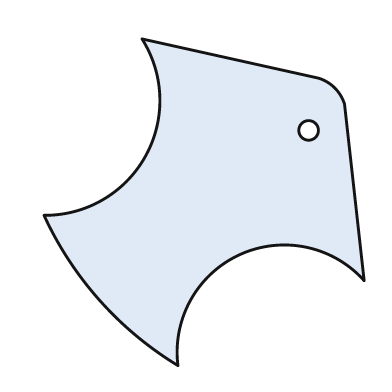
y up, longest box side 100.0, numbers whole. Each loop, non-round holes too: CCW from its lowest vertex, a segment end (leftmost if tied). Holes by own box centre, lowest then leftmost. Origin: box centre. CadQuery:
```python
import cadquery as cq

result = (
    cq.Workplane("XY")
    .moveTo(-8.0, -50.0)
    .threePointArc((11.0, -16.0), (49.0, -24.0))
    .lineTo(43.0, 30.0)
    .threePointArc((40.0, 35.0), (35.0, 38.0))
    .lineTo(-19.0, 50.0)
    .threePointArc((-18.0, 14.0), (-49.0, -4.0))
    .threePointArc((-32.0, -30.0), (-8.0, -50.0))
    .close()
    .moveTo(32.0, 22.0)
    .circle(3.0)
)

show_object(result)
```